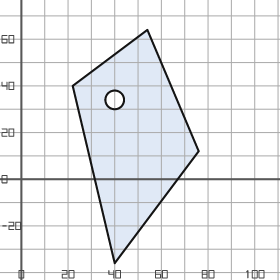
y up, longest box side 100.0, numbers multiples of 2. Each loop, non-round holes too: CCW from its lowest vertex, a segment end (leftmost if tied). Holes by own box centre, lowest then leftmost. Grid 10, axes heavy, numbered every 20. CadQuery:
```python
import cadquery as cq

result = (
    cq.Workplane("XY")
    .moveTo(40.0, -36.0)
    .lineTo(76.0, 12.0)
    .lineTo(54.0, 64.0)
    .lineTo(22.0, 40.0)
    .close()
    .moveTo(40.0, 34.0)
    .circle(4.0)
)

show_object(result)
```